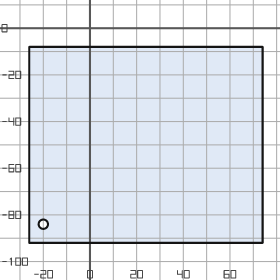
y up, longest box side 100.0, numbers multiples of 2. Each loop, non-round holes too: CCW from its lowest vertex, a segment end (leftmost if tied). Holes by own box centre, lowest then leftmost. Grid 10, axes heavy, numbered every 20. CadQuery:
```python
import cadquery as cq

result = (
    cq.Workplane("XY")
    .moveTo(-26.0, -92.0)
    .lineTo(74.0, -92.0)
    .lineTo(74.0, -8.0)
    .lineTo(-26.0, -8.0)
    .close()
    .moveTo(-20.0, -84.0)
    .circle(2.0)
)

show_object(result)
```